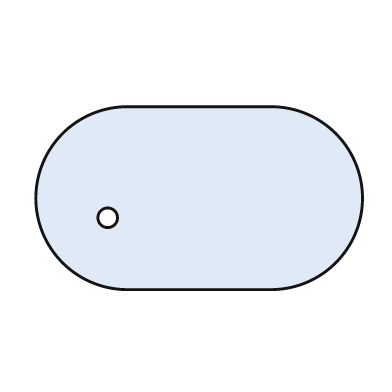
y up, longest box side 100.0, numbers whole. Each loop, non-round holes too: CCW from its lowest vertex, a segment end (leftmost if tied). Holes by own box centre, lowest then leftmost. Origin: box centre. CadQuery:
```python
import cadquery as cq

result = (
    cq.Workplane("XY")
    .moveTo(-22.0, -28.0)
    .lineTo(22.0, -28.0)
    .threePointArc((50.0, 0.0), (22.0, 28.0))
    .lineTo(-22.0, 28.0)
    .threePointArc((-50.0, 0.0), (-22.0, -28.0))
    .close()
    .moveTo(-28.0, -6.0)
    .circle(3.0)
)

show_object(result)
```